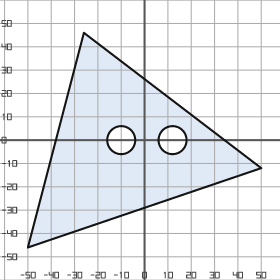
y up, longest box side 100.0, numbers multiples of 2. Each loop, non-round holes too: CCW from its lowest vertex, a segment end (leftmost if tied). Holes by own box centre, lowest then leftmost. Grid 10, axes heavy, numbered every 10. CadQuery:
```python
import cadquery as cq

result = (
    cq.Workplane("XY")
    .moveTo(-50.0, -46.0)
    .lineTo(50.0, -12.0)
    .lineTo(-26.0, 46.0)
    .close()
    .moveTo(-10.0, 0.0)
    .circle(6.0)
    .moveTo(12.0, 0.0)
    .circle(6.0)
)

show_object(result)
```